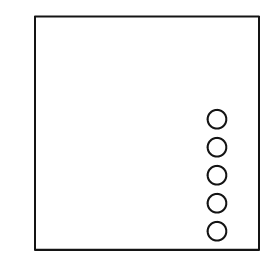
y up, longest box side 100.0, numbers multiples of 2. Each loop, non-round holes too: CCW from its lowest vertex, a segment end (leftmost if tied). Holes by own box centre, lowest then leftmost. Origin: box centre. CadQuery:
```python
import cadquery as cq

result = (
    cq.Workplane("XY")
    .moveTo(-48.0, -50.0)
    .lineTo(48.0, -50.0)
    .lineTo(48.0, 50.0)
    .lineTo(-48.0, 50.0)
    .close()
    .moveTo(30.0, -42.0)
    .circle(4.0)
    .moveTo(30.0, -30.0)
    .circle(4.0)
    .moveTo(30.0, -18.0)
    .circle(4.0)
    .moveTo(30.0, -6.0)
    .circle(4.0)
    .moveTo(30.0, 6.0)
    .circle(4.0)
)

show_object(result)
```